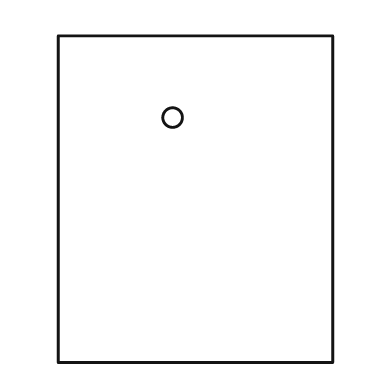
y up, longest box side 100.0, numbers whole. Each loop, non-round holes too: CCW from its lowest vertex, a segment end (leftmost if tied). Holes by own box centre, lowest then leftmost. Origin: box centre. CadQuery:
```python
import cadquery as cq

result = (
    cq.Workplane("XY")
    .moveTo(-42.0, -50.0)
    .lineTo(42.0, -50.0)
    .lineTo(42.0, 50.0)
    .lineTo(-42.0, 50.0)
    .close()
    .moveTo(-7.0, 25.0)
    .circle(3.0)
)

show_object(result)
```